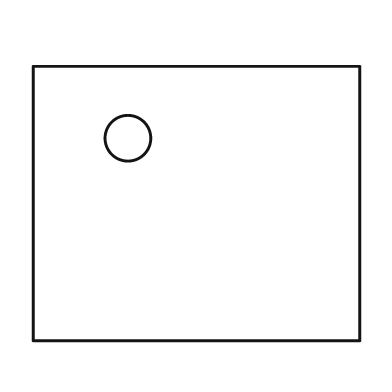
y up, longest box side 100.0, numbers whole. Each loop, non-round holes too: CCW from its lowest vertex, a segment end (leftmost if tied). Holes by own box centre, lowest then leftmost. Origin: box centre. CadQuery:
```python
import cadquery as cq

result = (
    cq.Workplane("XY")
    .moveTo(-50.0, -42.0)
    .lineTo(50.0, -42.0)
    .lineTo(50.0, 42.0)
    .lineTo(-50.0, 42.0)
    .close()
    .moveTo(-21.0, 20.0)
    .circle(7.0)
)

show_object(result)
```